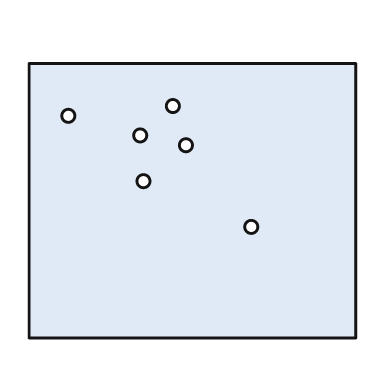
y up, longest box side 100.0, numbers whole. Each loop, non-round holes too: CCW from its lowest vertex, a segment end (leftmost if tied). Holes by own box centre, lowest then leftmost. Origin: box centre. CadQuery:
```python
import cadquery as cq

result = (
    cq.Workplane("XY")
    .moveTo(-50.0, -42.0)
    .lineTo(50.0, -42.0)
    .lineTo(50.0, 42.0)
    .lineTo(-50.0, 42.0)
    .close()
    .moveTo(18.0, -8.0)
    .circle(2.0)
    .moveTo(-15.0, 6.0)
    .circle(2.0)
    .moveTo(-2.0, 17.0)
    .circle(2.0)
    .moveTo(-16.0, 20.0)
    .circle(2.0)
    .moveTo(-38.0, 26.0)
    .circle(2.0)
    .moveTo(-6.0, 29.0)
    .circle(2.0)
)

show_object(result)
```